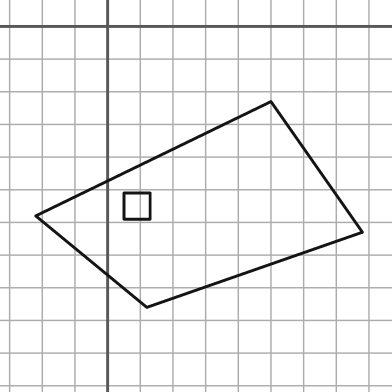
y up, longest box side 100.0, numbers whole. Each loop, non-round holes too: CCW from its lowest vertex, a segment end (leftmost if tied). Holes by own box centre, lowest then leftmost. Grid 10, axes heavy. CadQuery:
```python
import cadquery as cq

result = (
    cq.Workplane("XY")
    .moveTo(12.0, -86.0)
    .lineTo(78.0, -63.0)
    .lineTo(50.0, -23.0)
    .lineTo(-22.0, -58.0)
    .close()
    .moveTo(5.0, -59.0)
    .lineTo(13.0, -59.0)
    .lineTo(13.0, -51.0)
    .lineTo(5.0, -51.0)
    .close()
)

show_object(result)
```